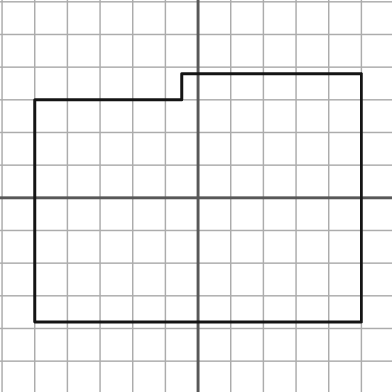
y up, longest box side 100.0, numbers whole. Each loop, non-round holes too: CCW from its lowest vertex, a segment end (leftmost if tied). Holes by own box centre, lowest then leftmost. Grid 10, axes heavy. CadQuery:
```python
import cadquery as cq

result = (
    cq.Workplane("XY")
    .moveTo(-50.0, -38.0)
    .lineTo(50.0, -38.0)
    .lineTo(50.0, 38.0)
    .lineTo(-5.0, 38.0)
    .lineTo(-5.0, 30.0)
    .lineTo(-50.0, 30.0)
    .close()
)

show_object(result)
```